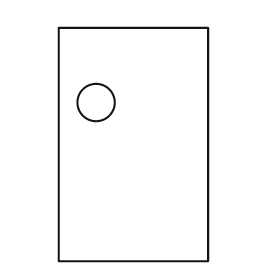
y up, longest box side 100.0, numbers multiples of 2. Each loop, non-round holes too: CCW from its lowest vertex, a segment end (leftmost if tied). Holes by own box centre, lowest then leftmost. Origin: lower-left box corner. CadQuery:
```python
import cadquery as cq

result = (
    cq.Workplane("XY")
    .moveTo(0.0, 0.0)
    .lineTo(64.0, 0.0)
    .lineTo(64.0, 100.0)
    .lineTo(0.0, 100.0)
    .close()
    .moveTo(16.0, 68.0)
    .circle(8.0)
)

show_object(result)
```